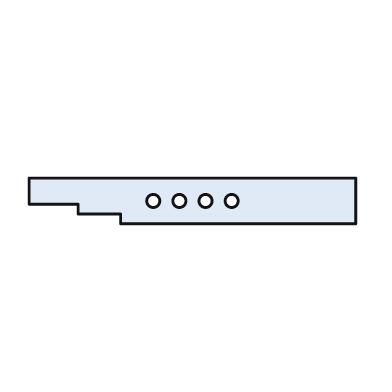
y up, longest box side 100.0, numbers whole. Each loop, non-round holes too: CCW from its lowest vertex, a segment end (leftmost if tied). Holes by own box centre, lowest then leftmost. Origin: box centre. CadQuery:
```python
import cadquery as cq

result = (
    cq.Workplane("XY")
    .moveTo(-22.0, -7.0)
    .lineTo(50.0, -7.0)
    .lineTo(50.0, 7.0)
    .lineTo(-50.0, 7.0)
    .lineTo(-50.0, -1.0)
    .lineTo(-35.0, -1.0)
    .lineTo(-35.0, -4.0)
    .lineTo(-22.0, -4.0)
    .close()
    .moveTo(-12.0, 0.0)
    .circle(2.0)
    .moveTo(-4.0, 0.0)
    .circle(2.0)
    .moveTo(4.0, 0.0)
    .circle(2.0)
    .moveTo(12.0, 0.0)
    .circle(2.0)
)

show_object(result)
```